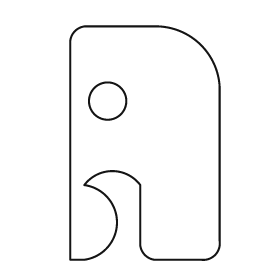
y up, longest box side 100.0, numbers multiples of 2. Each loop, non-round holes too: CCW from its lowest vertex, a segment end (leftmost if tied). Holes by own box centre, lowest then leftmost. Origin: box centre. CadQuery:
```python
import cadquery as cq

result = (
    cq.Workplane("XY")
    .moveTo(-32.0, -50.0)
    .lineTo(-26.0, -50.0)
    .threePointArc((-12.0, -34.0), (-26.0, -18.0))
    .threePointArc((-14.0, -12.0), (-2.0, -18.0))
    .lineTo(-2.0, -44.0)
    .threePointArc((0.0, -48.0), (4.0, -50.0))
    .lineTo(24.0, -50.0)
    .threePointArc((30.0, -48.0), (32.0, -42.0))
    .lineTo(32.0, 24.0)
    .threePointArc((24.0, 42.0), (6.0, 50.0))
    .lineTo(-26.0, 50.0)
    .threePointArc((-30.0, 48.0), (-32.0, 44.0))
    .close()
    .moveTo(-16.0, 18.0)
    .circle(8.0)
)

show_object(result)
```